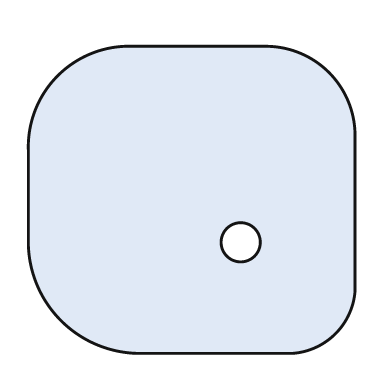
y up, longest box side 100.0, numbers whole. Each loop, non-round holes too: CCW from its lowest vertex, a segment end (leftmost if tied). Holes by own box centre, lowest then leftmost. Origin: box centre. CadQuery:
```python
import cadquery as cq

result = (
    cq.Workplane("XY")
    .moveTo(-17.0, -47.0)
    .lineTo(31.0, -47.0)
    .threePointArc((44.0, -41.0), (50.0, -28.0))
    .lineTo(50.0, 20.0)
    .threePointArc((42.0, 39.0), (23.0, 47.0))
    .lineTo(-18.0, 47.0)
    .threePointArc((-41.0, 38.0), (-50.0, 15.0))
    .lineTo(-50.0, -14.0)
    .threePointArc((-40.0, -37.0), (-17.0, -47.0))
    .close()
    .moveTo(15.0, -13.0)
    .circle(6.0)
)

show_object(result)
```